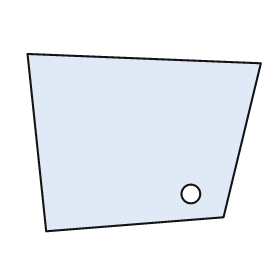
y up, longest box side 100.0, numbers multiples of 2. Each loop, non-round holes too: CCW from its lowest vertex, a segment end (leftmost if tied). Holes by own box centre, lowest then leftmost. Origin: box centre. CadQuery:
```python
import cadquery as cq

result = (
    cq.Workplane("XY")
    .moveTo(-42.0, -38.0)
    .lineTo(34.0, -32.0)
    .lineTo(50.0, 34.0)
    .lineTo(-50.0, 38.0)
    .close()
    .moveTo(20.0, -22.0)
    .circle(4.0)
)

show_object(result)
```